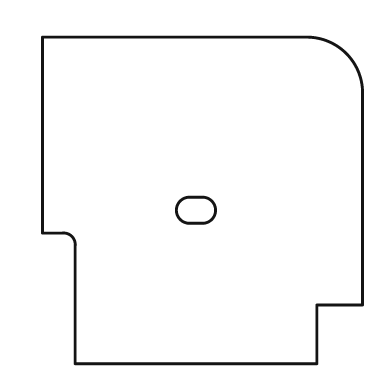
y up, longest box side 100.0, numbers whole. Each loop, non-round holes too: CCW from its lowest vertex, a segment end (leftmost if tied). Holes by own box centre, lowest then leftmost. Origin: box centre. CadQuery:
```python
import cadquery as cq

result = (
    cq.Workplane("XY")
    .moveTo(-39.0, -50.0)
    .lineTo(35.0, -50.0)
    .lineTo(35.0, -32.0)
    .lineTo(49.0, -32.0)
    .lineTo(49.0, 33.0)
    .threePointArc((44.0, 45.0), (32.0, 50.0))
    .lineTo(-49.0, 50.0)
    .lineTo(-49.0, -10.0)
    .lineTo(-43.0, -10.0)
    .threePointArc((-40.0, -11.0), (-39.0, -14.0))
    .close()
    .moveTo(-4.0, -7.0)
    .lineTo(0.0, -7.0)
    .threePointArc((4.0, -3.0), (0.0, 1.0))
    .lineTo(-4.0, 1.0)
    .threePointArc((-8.0, -3.0), (-4.0, -7.0))
    .close()
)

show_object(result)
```